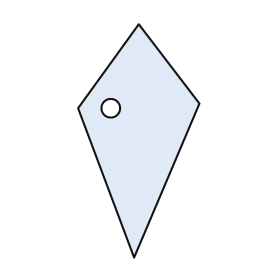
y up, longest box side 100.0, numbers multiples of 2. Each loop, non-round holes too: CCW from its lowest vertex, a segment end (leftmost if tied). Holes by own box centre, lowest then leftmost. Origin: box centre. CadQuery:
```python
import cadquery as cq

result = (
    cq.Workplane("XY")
    .moveTo(-2.0, -50.0)
    .lineTo(26.0, 16.0)
    .lineTo(0.0, 50.0)
    .lineTo(-26.0, 14.0)
    .close()
    .moveTo(-12.0, 14.0)
    .circle(4.0)
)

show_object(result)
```